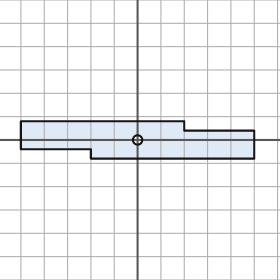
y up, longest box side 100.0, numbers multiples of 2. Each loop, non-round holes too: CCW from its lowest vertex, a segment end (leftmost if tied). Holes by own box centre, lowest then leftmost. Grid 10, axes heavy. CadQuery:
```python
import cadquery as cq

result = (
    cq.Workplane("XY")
    .moveTo(-20.0, -8.0)
    .lineTo(50.0, -8.0)
    .lineTo(50.0, 4.0)
    .lineTo(20.0, 4.0)
    .lineTo(20.0, 8.0)
    .lineTo(-50.0, 8.0)
    .lineTo(-50.0, -4.0)
    .lineTo(-20.0, -4.0)
    .close()
    .moveTo(0.0, 0.0)
    .circle(2.0)
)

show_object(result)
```